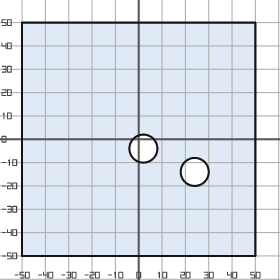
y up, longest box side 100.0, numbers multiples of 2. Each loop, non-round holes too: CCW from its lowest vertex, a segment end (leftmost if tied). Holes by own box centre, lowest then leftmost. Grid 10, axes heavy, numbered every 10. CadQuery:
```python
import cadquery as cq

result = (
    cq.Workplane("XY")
    .moveTo(-50.0, -50.0)
    .lineTo(50.0, -50.0)
    .lineTo(50.0, 50.0)
    .lineTo(-50.0, 50.0)
    .close()
    .moveTo(24.0, -14.0)
    .circle(6.0)
    .moveTo(2.0, -4.0)
    .circle(6.0)
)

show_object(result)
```